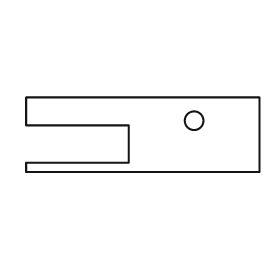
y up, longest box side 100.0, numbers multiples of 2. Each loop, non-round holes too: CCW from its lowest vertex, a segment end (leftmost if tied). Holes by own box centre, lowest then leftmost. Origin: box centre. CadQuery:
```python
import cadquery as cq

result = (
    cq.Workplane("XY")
    .moveTo(-50.0, -16.0)
    .lineTo(50.0, -16.0)
    .lineTo(50.0, 16.0)
    .lineTo(-50.0, 16.0)
    .lineTo(-50.0, 4.0)
    .lineTo(-6.0, 4.0)
    .lineTo(-6.0, -12.0)
    .lineTo(-50.0, -12.0)
    .close()
    .moveTo(22.0, 6.0)
    .circle(4.0)
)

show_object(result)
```